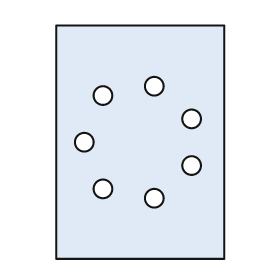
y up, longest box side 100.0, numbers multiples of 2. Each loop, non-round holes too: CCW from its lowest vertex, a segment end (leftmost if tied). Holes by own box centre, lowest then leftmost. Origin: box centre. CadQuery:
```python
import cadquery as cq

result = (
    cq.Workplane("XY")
    .moveTo(-36.0, -50.0)
    .lineTo(36.0, -50.0)
    .lineTo(36.0, 50.0)
    .lineTo(-36.0, 50.0)
    .close()
    .moveTo(6.0, -24.0)
    .circle(4.0)
    .moveTo(-16.0, -20.0)
    .circle(4.0)
    .moveTo(22.0, -10.0)
    .circle(4.0)
    .moveTo(-24.0, 0.0)
    .circle(4.0)
    .moveTo(22.0, 10.0)
    .circle(4.0)
    .moveTo(-16.0, 20.0)
    .circle(4.0)
    .moveTo(6.0, 24.0)
    .circle(4.0)
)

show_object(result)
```